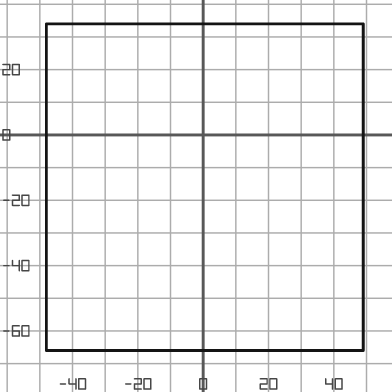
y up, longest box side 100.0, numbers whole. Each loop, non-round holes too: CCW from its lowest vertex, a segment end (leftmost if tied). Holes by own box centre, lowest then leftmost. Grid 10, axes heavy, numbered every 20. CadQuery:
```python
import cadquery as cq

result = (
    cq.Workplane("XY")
    .moveTo(-48.0, -66.0)
    .lineTo(49.0, -66.0)
    .lineTo(49.0, 34.0)
    .lineTo(-48.0, 34.0)
    .close()
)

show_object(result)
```